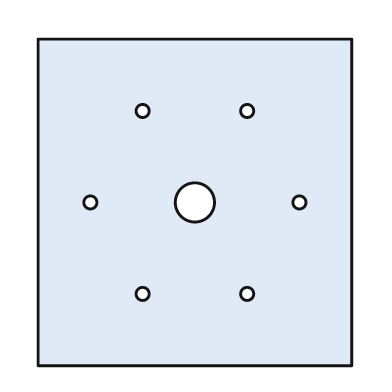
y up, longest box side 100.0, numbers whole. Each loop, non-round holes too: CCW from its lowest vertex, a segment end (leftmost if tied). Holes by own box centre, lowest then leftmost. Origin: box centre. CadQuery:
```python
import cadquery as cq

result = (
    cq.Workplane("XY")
    .moveTo(-48.0, -50.0)
    .lineTo(48.0, -50.0)
    .lineTo(48.0, 50.0)
    .lineTo(-48.0, 50.0)
    .close()
    .moveTo(-16.0, -28.0)
    .circle(2.0)
    .moveTo(16.0, -28.0)
    .circle(2.0)
    .moveTo(-32.0, 0.0)
    .circle(2.0)
    .moveTo(0.0, 0.0)
    .circle(6.0)
    .moveTo(32.0, 0.0)
    .circle(2.0)
    .moveTo(-16.0, 28.0)
    .circle(2.0)
    .moveTo(16.0, 28.0)
    .circle(2.0)
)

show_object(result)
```